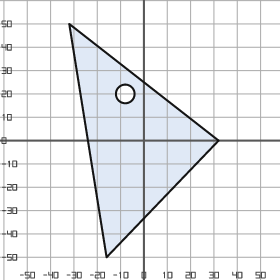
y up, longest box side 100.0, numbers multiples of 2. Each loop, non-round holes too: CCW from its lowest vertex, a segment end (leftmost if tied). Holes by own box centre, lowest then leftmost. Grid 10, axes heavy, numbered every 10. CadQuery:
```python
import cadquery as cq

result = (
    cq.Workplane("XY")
    .moveTo(-16.0, -50.0)
    .lineTo(32.0, 0.0)
    .lineTo(-32.0, 50.0)
    .close()
    .moveTo(-8.0, 20.0)
    .circle(4.0)
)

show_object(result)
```